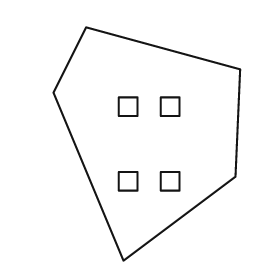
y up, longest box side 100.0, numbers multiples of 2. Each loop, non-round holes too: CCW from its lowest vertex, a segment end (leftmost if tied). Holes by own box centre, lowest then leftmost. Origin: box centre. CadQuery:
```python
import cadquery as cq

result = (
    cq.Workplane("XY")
    .moveTo(-10.0, -50.0)
    .lineTo(38.0, -14.0)
    .lineTo(40.0, 32.0)
    .lineTo(-26.0, 50.0)
    .lineTo(-40.0, 22.0)
    .close()
    .moveTo(-12.0, -20.0)
    .lineTo(-4.0, -20.0)
    .lineTo(-4.0, -12.0)
    .lineTo(-12.0, -12.0)
    .close()
    .moveTo(6.0, -20.0)
    .lineTo(14.0, -20.0)
    .lineTo(14.0, -12.0)
    .lineTo(6.0, -12.0)
    .close()
    .moveTo(-12.0, 12.0)
    .lineTo(-4.0, 12.0)
    .lineTo(-4.0, 20.0)
    .lineTo(-12.0, 20.0)
    .close()
    .moveTo(6.0, 12.0)
    .lineTo(14.0, 12.0)
    .lineTo(14.0, 20.0)
    .lineTo(6.0, 20.0)
    .close()
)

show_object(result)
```